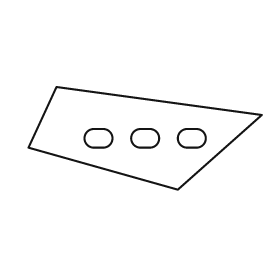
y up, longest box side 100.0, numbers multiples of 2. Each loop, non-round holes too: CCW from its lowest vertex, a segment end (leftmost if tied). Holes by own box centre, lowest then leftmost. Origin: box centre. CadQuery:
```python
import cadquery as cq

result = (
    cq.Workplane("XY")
    .moveTo(14.0, -22.0)
    .lineTo(50.0, 10.0)
    .lineTo(-38.0, 22.0)
    .lineTo(-50.0, -4.0)
    .close()
    .moveTo(-22.0, -4.0)
    .lineTo(-18.0, -4.0)
    .threePointArc((-14.0, 0.0), (-18.0, 4.0))
    .lineTo(-22.0, 4.0)
    .threePointArc((-26.0, 0.0), (-22.0, -4.0))
    .close()
    .moveTo(-2.0, -4.0)
    .lineTo(2.0, -4.0)
    .threePointArc((6.0, 0.0), (2.0, 4.0))
    .lineTo(-2.0, 4.0)
    .threePointArc((-6.0, 0.0), (-2.0, -4.0))
    .close()
    .moveTo(18.0, -4.0)
    .lineTo(22.0, -4.0)
    .threePointArc((26.0, 0.0), (22.0, 4.0))
    .lineTo(18.0, 4.0)
    .threePointArc((14.0, 0.0), (18.0, -4.0))
    .close()
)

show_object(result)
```